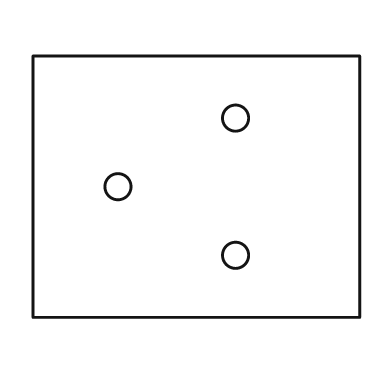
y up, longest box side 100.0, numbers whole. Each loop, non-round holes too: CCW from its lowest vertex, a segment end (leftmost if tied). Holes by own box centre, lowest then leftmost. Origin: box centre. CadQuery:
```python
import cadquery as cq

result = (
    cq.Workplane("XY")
    .moveTo(-50.0, -40.0)
    .lineTo(50.0, -40.0)
    .lineTo(50.0, 40.0)
    .lineTo(-50.0, 40.0)
    .close()
    .moveTo(12.0, -21.0)
    .circle(4.0)
    .moveTo(-24.0, 0.0)
    .circle(4.0)
    .moveTo(12.0, 21.0)
    .circle(4.0)
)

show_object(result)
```